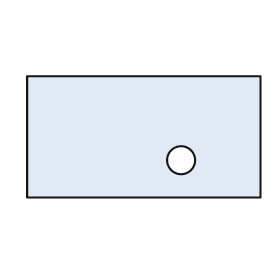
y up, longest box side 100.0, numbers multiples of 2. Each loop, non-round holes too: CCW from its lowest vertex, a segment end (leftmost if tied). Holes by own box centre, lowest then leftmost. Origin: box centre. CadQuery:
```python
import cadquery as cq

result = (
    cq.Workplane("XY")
    .moveTo(-50.0, -26.0)
    .lineTo(50.0, -26.0)
    .lineTo(50.0, 26.0)
    .lineTo(-50.0, 26.0)
    .close()
    .moveTo(16.0, -10.0)
    .circle(6.0)
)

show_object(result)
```